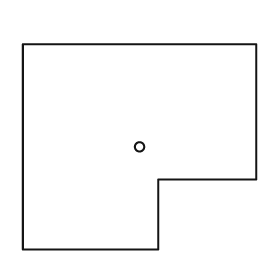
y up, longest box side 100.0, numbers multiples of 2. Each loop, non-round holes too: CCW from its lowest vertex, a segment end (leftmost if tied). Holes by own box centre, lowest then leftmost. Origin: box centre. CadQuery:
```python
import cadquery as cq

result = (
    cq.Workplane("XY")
    .moveTo(-50.0, -44.0)
    .lineTo(8.0, -44.0)
    .lineTo(8.0, -14.0)
    .lineTo(50.0, -14.0)
    .lineTo(50.0, 44.0)
    .lineTo(-50.0, 44.0)
    .close()
    .moveTo(0.0, 0.0)
    .circle(2.0)
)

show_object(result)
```